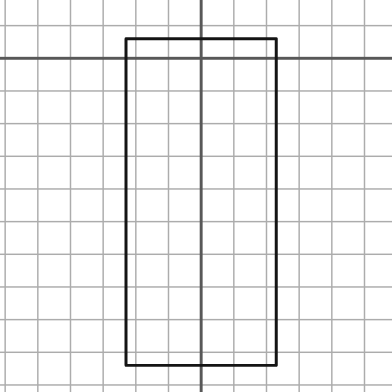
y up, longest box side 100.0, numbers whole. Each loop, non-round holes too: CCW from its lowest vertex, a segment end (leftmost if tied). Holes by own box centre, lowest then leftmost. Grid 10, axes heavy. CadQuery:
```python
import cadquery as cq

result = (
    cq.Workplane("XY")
    .moveTo(-23.0, -94.0)
    .lineTo(23.0, -94.0)
    .lineTo(23.0, 6.0)
    .lineTo(-23.0, 6.0)
    .close()
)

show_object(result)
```